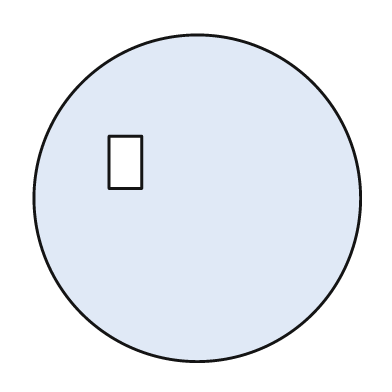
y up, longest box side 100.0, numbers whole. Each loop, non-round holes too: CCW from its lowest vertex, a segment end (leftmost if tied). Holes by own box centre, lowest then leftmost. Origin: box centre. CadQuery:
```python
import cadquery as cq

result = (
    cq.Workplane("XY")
    .moveTo(0.0, 0.0)
    .circle(50.0)
    .moveTo(-27.0, 3.0)
    .lineTo(-17.0, 3.0)
    .lineTo(-17.0, 19.0)
    .lineTo(-27.0, 19.0)
    .close()
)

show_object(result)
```